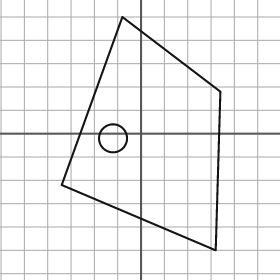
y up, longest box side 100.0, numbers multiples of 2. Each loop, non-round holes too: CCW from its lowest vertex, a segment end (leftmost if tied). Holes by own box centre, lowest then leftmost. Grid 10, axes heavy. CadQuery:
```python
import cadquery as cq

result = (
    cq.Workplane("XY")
    .moveTo(32.0, -50.0)
    .lineTo(34.0, 18.0)
    .lineTo(-8.0, 50.0)
    .lineTo(-34.0, -22.0)
    .close()
    .moveTo(-12.0, -2.0)
    .circle(6.0)
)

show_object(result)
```